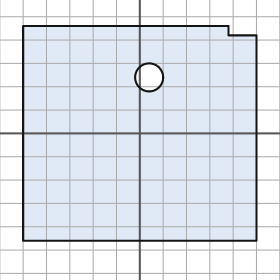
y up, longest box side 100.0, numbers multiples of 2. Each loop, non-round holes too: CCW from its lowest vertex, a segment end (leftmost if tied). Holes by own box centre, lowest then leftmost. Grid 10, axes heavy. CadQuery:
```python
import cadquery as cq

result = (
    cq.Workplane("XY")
    .moveTo(-50.0, -46.0)
    .lineTo(50.0, -46.0)
    .lineTo(50.0, 42.0)
    .lineTo(38.0, 42.0)
    .lineTo(38.0, 46.0)
    .lineTo(-50.0, 46.0)
    .close()
    .moveTo(4.0, 24.0)
    .circle(6.0)
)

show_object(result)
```